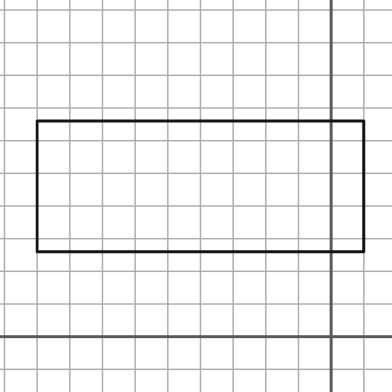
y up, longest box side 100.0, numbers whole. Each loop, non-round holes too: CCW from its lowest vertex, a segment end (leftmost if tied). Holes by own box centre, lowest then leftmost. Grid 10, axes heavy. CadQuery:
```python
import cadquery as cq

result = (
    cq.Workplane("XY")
    .moveTo(-90.0, 26.0)
    .lineTo(10.0, 26.0)
    .lineTo(10.0, 66.0)
    .lineTo(-90.0, 66.0)
    .close()
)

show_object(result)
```